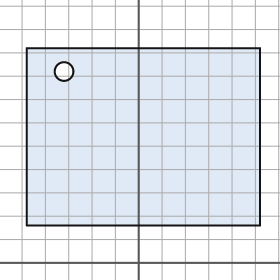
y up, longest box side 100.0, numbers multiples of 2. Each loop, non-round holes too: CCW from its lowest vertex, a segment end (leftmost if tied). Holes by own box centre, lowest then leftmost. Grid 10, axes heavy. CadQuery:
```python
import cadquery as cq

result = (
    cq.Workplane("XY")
    .moveTo(-48.0, 16.0)
    .lineTo(52.0, 16.0)
    .lineTo(52.0, 92.0)
    .lineTo(-48.0, 92.0)
    .close()
    .moveTo(-32.0, 82.0)
    .circle(4.0)
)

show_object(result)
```